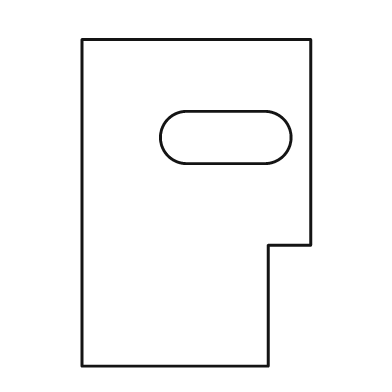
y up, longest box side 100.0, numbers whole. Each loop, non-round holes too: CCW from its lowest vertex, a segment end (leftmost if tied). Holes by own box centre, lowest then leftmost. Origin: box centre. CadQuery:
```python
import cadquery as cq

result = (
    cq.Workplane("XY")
    .moveTo(-35.0, -50.0)
    .lineTo(22.0, -50.0)
    .lineTo(22.0, -13.0)
    .lineTo(35.0, -13.0)
    .lineTo(35.0, 50.0)
    .lineTo(-35.0, 50.0)
    .close()
    .moveTo(-3.0, 12.0)
    .lineTo(21.0, 12.0)
    .threePointArc((29.0, 20.0), (21.0, 28.0))
    .lineTo(-3.0, 28.0)
    .threePointArc((-11.0, 20.0), (-3.0, 12.0))
    .close()
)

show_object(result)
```